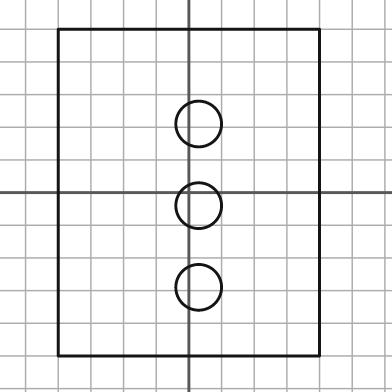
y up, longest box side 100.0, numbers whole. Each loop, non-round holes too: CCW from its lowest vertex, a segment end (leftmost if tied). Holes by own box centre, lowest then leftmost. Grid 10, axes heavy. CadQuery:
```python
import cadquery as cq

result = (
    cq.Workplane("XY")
    .moveTo(-40.0, -50.0)
    .lineTo(40.0, -50.0)
    .lineTo(40.0, 50.0)
    .lineTo(-40.0, 50.0)
    .close()
    .moveTo(3.0, -29.0)
    .circle(7.0)
    .moveTo(3.0, -4.0)
    .circle(7.0)
    .moveTo(3.0, 21.0)
    .circle(7.0)
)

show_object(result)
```